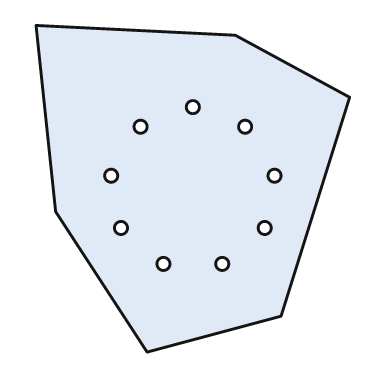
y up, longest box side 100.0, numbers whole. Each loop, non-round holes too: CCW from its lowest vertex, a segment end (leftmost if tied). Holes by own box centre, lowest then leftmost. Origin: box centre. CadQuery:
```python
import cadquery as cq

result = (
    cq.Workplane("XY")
    .moveTo(-14.0, -50.0)
    .lineTo(27.0, -39.0)
    .lineTo(48.0, 28.0)
    .lineTo(13.0, 47.0)
    .lineTo(-48.0, 50.0)
    .lineTo(-42.0, -7.0)
    .close()
    .moveTo(-9.0, -23.0)
    .circle(2.0)
    .moveTo(9.0, -23.0)
    .circle(2.0)
    .moveTo(-22.0, -12.0)
    .circle(2.0)
    .moveTo(22.0, -12.0)
    .circle(2.0)
    .moveTo(-25.0, 4.0)
    .circle(2.0)
    .moveTo(25.0, 4.0)
    .circle(2.0)
    .moveTo(-16.0, 19.0)
    .circle(2.0)
    .moveTo(16.0, 19.0)
    .circle(2.0)
    .moveTo(0.0, 25.0)
    .circle(2.0)
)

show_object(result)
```